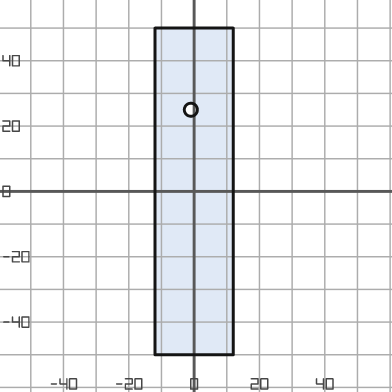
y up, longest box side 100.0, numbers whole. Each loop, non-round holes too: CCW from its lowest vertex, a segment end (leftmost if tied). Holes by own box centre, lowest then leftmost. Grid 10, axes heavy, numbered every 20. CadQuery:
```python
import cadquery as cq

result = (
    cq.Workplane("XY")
    .moveTo(-12.0, -50.0)
    .lineTo(12.0, -50.0)
    .lineTo(12.0, 50.0)
    .lineTo(-12.0, 50.0)
    .close()
    .moveTo(-1.0, 25.0)
    .circle(2.0)
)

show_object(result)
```